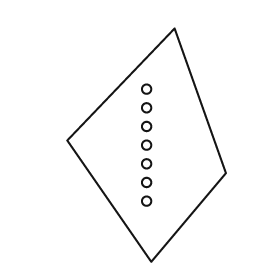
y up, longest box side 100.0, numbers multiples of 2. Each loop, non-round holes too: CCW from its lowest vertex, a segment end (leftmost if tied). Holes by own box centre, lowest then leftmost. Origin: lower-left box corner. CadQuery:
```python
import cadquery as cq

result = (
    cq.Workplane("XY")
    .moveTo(36.0, 0.0)
    .lineTo(68.0, 38.0)
    .lineTo(46.0, 100.0)
    .lineTo(0.0, 52.0)
    .close()
    .moveTo(34.0, 26.0)
    .circle(2.0)
    .moveTo(34.0, 34.0)
    .circle(2.0)
    .moveTo(34.0, 42.0)
    .circle(2.0)
    .moveTo(34.0, 50.0)
    .circle(2.0)
    .moveTo(34.0, 58.0)
    .circle(2.0)
    .moveTo(34.0, 66.0)
    .circle(2.0)
    .moveTo(34.0, 74.0)
    .circle(2.0)
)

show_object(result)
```